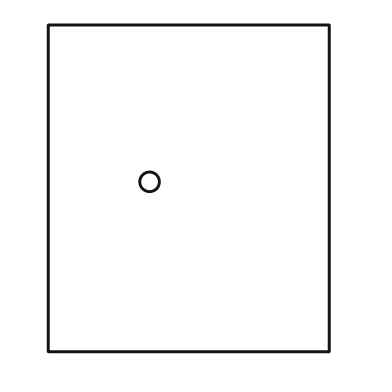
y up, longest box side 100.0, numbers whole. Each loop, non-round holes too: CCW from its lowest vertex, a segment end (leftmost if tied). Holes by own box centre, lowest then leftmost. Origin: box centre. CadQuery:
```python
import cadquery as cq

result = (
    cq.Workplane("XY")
    .moveTo(-43.0, -50.0)
    .lineTo(43.0, -50.0)
    .lineTo(43.0, 50.0)
    .lineTo(-43.0, 50.0)
    .close()
    .moveTo(-12.0, 2.0)
    .circle(3.0)
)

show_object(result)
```